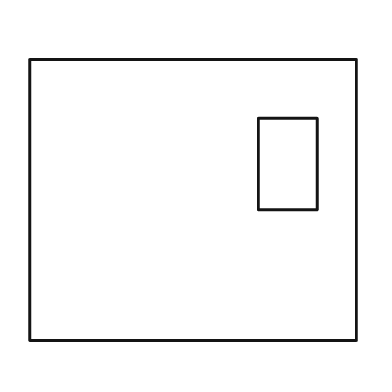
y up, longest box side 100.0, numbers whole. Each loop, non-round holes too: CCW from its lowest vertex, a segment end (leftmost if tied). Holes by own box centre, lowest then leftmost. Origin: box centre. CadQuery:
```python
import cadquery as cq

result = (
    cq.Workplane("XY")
    .moveTo(-50.0, -43.0)
    .lineTo(50.0, -43.0)
    .lineTo(50.0, 43.0)
    .lineTo(-50.0, 43.0)
    .close()
    .moveTo(20.0, -3.0)
    .lineTo(38.0, -3.0)
    .lineTo(38.0, 25.0)
    .lineTo(20.0, 25.0)
    .close()
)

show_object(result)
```